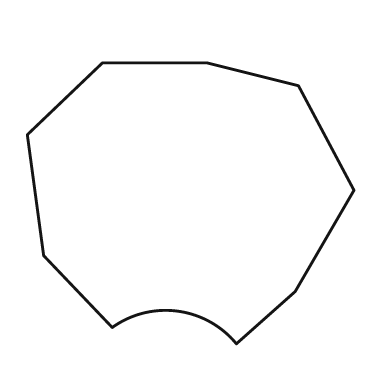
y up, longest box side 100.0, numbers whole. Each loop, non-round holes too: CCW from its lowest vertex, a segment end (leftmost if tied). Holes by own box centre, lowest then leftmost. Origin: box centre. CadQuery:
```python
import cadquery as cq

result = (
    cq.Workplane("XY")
    .moveTo(14.0, -43.0)
    .lineTo(32.0, -27.0)
    .lineTo(50.0, 4.0)
    .lineTo(33.0, 36.0)
    .lineTo(5.0, 43.0)
    .lineTo(-27.0, 43.0)
    .lineTo(-50.0, 21.0)
    .lineTo(-45.0, -16.0)
    .lineTo(-24.0, -38.0)
    .threePointArc((-4.0, -33.0), (14.0, -43.0))
    .close()
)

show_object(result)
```